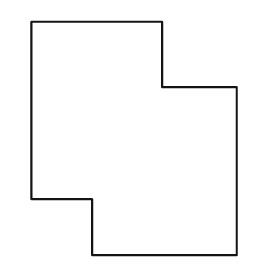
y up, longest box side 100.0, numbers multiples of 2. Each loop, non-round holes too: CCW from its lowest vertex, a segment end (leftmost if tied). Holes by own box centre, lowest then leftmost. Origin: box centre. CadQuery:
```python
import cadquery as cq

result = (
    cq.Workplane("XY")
    .moveTo(-18.0, -50.0)
    .lineTo(44.0, -50.0)
    .lineTo(44.0, 22.0)
    .lineTo(12.0, 22.0)
    .lineTo(12.0, 50.0)
    .lineTo(-44.0, 50.0)
    .lineTo(-44.0, -26.0)
    .lineTo(-18.0, -26.0)
    .close()
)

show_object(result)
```